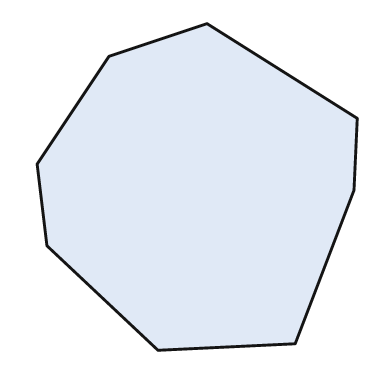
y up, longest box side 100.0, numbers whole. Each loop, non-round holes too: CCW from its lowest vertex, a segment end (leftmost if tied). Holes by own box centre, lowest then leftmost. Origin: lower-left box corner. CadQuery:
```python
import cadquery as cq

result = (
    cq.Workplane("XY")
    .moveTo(37.0, 0.0)
    .lineTo(79.0, 2.0)
    .lineTo(97.0, 49.0)
    .lineTo(98.0, 71.0)
    .lineTo(52.0, 100.0)
    .lineTo(22.0, 90.0)
    .lineTo(0.0, 57.0)
    .lineTo(3.0, 32.0)
    .close()
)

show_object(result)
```